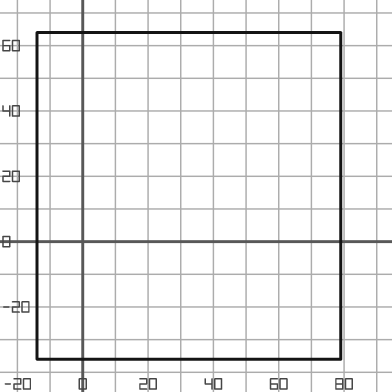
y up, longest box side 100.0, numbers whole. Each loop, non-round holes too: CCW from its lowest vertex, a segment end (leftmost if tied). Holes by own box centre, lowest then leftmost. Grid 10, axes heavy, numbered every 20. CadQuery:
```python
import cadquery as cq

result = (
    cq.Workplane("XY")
    .moveTo(-14.0, -36.0)
    .lineTo(79.0, -36.0)
    .lineTo(79.0, 64.0)
    .lineTo(-14.0, 64.0)
    .close()
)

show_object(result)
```